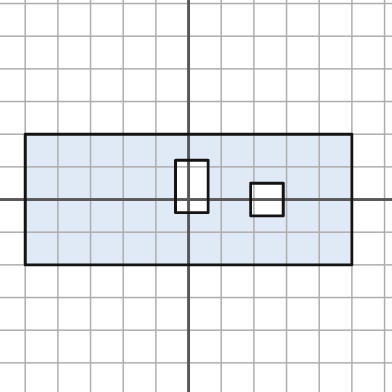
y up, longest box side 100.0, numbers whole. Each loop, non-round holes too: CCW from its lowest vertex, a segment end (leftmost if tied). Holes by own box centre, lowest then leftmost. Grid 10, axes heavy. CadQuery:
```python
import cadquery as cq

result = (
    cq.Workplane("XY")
    .moveTo(-50.0, -20.0)
    .lineTo(50.0, -20.0)
    .lineTo(50.0, 20.0)
    .lineTo(-50.0, 20.0)
    .close()
    .moveTo(19.0, -5.0)
    .lineTo(29.0, -5.0)
    .lineTo(29.0, 5.0)
    .lineTo(19.0, 5.0)
    .close()
    .moveTo(-4.0, -4.0)
    .lineTo(6.0, -4.0)
    .lineTo(6.0, 12.0)
    .lineTo(-4.0, 12.0)
    .close()
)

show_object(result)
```